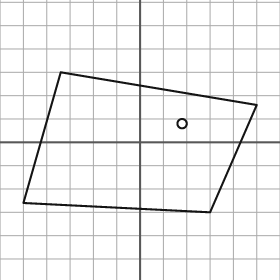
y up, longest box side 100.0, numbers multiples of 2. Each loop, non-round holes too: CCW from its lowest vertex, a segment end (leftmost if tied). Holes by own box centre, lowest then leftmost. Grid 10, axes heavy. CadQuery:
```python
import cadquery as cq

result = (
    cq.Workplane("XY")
    .moveTo(30.0, -30.0)
    .lineTo(50.0, 16.0)
    .lineTo(-34.0, 30.0)
    .lineTo(-50.0, -26.0)
    .close()
    .moveTo(18.0, 8.0)
    .circle(2.0)
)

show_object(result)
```